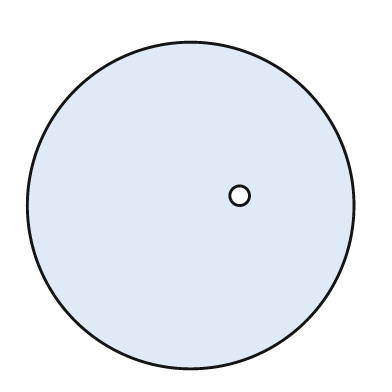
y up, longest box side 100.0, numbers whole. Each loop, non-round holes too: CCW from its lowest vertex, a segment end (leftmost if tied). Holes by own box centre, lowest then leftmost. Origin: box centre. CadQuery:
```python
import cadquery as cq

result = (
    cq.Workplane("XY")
    .moveTo(0.0, 0.0)
    .circle(50.0)
    .moveTo(15.0, 3.0)
    .circle(3.0)
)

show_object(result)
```